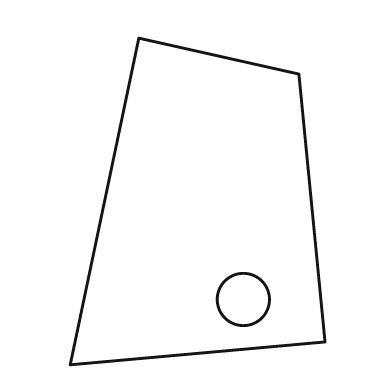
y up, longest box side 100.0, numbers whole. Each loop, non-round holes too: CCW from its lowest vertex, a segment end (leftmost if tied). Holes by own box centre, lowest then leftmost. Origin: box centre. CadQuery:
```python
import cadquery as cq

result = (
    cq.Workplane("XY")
    .moveTo(-39.0, -50.0)
    .lineTo(39.0, -43.0)
    .lineTo(31.0, 39.0)
    .lineTo(-18.0, 50.0)
    .close()
    .moveTo(14.0, -30.0)
    .circle(8.0)
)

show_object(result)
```